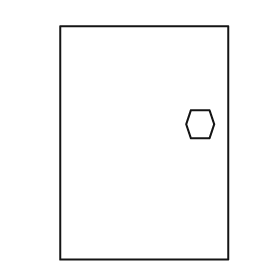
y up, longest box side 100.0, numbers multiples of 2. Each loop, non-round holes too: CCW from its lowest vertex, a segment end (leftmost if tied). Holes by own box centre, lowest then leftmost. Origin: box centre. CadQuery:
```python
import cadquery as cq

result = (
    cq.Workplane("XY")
    .moveTo(-36.0, -50.0)
    .lineTo(36.0, -50.0)
    .lineTo(36.0, 50.0)
    .lineTo(-36.0, 50.0)
    .close()
    .moveTo(20.0, 2.0)
    .lineTo(28.0, 2.0)
    .lineTo(30.0, 8.0)
    .lineTo(28.0, 14.0)
    .lineTo(20.0, 14.0)
    .lineTo(18.0, 8.0)
    .close()
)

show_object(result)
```